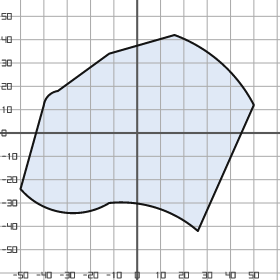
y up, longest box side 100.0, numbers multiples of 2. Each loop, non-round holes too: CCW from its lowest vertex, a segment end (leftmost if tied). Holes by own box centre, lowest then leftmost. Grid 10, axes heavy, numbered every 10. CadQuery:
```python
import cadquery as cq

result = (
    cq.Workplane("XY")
    .moveTo(26.0, -42.0)
    .lineTo(50.0, 12.0)
    .threePointArc((36.0, 30.0), (16.0, 42.0))
    .lineTo(-12.0, 34.0)
    .lineTo(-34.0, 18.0)
    .threePointArc((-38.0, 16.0), (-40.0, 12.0))
    .lineTo(-50.0, -24.0)
    .threePointArc((-32.0, -34.0), (-12.0, -30.0))
    .threePointArc((8.0, -32.0), (26.0, -42.0))
    .close()
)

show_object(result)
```